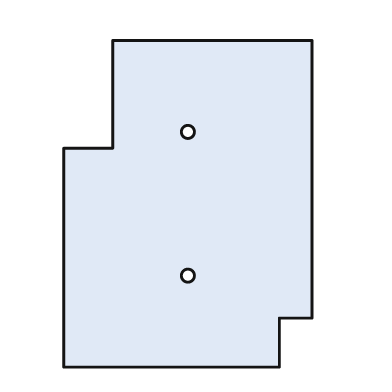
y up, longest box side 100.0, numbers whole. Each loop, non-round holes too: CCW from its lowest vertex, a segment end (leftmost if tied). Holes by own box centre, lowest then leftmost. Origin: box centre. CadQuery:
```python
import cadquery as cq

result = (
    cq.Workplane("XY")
    .moveTo(-38.0, -50.0)
    .lineTo(28.0, -50.0)
    .lineTo(28.0, -35.0)
    .lineTo(38.0, -35.0)
    .lineTo(38.0, 50.0)
    .lineTo(-23.0, 50.0)
    .lineTo(-23.0, 17.0)
    .lineTo(-38.0, 17.0)
    .close()
    .moveTo(0.0, -22.0)
    .circle(2.0)
    .moveTo(0.0, 22.0)
    .circle(2.0)
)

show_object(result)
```